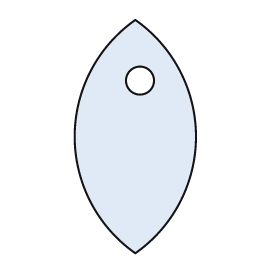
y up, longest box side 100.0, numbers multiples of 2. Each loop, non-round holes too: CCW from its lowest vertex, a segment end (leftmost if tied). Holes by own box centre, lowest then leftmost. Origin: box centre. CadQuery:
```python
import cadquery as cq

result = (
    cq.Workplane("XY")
    .moveTo(0.0, -50.0)
    .threePointArc((26.0, 0.0), (0.0, 50.0))
    .threePointArc((-26.0, 0.0), (0.0, -50.0))
    .close()
    .moveTo(2.0, 24.0)
    .circle(6.0)
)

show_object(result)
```